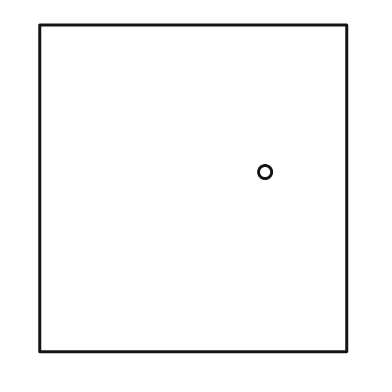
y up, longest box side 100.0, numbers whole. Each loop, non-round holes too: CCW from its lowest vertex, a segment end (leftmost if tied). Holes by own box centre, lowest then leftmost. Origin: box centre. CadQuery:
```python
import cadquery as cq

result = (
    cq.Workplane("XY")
    .moveTo(-47.0, -50.0)
    .lineTo(47.0, -50.0)
    .lineTo(47.0, 50.0)
    .lineTo(-47.0, 50.0)
    .close()
    .moveTo(22.0, 5.0)
    .circle(2.0)
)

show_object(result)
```